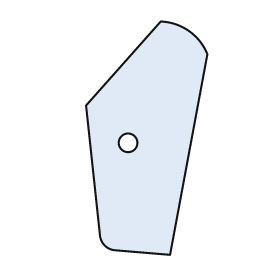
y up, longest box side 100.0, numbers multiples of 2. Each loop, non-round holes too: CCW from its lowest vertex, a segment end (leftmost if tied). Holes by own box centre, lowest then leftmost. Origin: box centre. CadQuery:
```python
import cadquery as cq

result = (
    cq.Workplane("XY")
    .moveTo(10.0, -50.0)
    .lineTo(26.0, 36.0)
    .threePointArc((18.0, 46.0), (6.0, 50.0))
    .lineTo(-26.0, 14.0)
    .lineTo(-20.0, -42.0)
    .threePointArc((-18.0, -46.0), (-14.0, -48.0))
    .close()
    .moveTo(-8.0, -2.0)
    .circle(4.0)
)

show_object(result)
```